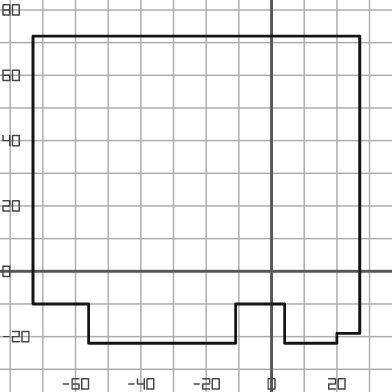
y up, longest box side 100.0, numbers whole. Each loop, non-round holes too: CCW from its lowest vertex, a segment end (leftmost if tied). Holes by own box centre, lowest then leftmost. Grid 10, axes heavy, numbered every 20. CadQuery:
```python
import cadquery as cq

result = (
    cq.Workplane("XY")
    .moveTo(-56.0, -22.0)
    .lineTo(-11.0, -22.0)
    .lineTo(-11.0, -10.0)
    .lineTo(4.0, -10.0)
    .lineTo(4.0, -22.0)
    .lineTo(20.0, -22.0)
    .lineTo(20.0, -19.0)
    .lineTo(27.0, -19.0)
    .lineTo(27.0, 72.0)
    .lineTo(-73.0, 72.0)
    .lineTo(-73.0, -10.0)
    .lineTo(-56.0, -10.0)
    .close()
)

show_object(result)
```